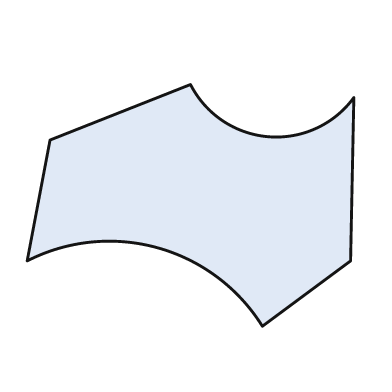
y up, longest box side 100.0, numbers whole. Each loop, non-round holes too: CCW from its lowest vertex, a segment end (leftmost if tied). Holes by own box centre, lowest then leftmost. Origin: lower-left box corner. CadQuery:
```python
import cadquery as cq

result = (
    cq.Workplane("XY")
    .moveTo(72.0, 0.0)
    .lineTo(99.0, 20.0)
    .lineTo(100.0, 70.0)
    .threePointArc((74.0, 58.0), (50.0, 74.0))
    .lineTo(7.0, 57.0)
    .lineTo(0.0, 20.0)
    .threePointArc((40.0, 24.0), (72.0, 0.0))
    .close()
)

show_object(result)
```